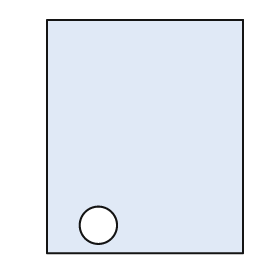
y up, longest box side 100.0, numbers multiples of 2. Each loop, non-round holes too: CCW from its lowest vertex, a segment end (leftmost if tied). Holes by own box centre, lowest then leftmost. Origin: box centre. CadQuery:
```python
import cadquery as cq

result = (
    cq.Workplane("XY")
    .moveTo(-42.0, -50.0)
    .lineTo(42.0, -50.0)
    .lineTo(42.0, 50.0)
    .lineTo(-42.0, 50.0)
    .close()
    .moveTo(-20.0, -38.0)
    .circle(8.0)
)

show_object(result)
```